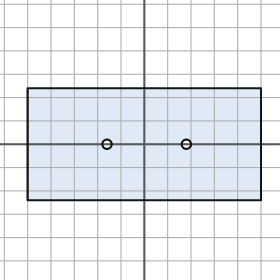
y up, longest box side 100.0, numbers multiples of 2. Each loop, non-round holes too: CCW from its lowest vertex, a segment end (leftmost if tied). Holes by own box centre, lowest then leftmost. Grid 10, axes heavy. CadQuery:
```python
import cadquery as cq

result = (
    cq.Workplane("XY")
    .moveTo(-50.0, -24.0)
    .lineTo(50.0, -24.0)
    .lineTo(50.0, 24.0)
    .lineTo(-50.0, 24.0)
    .close()
    .moveTo(-16.0, 0.0)
    .circle(2.0)
    .moveTo(18.0, 0.0)
    .circle(2.0)
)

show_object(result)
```